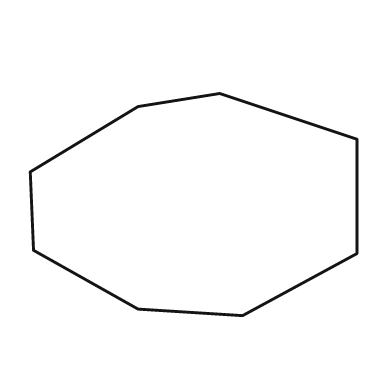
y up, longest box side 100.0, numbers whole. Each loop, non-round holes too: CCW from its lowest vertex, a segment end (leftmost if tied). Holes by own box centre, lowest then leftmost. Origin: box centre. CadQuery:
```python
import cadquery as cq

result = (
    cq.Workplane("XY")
    .moveTo(15.0, -34.0)
    .lineTo(50.0, -15.0)
    .lineTo(50.0, 20.0)
    .lineTo(8.0, 34.0)
    .lineTo(-17.0, 30.0)
    .lineTo(-50.0, 10.0)
    .lineTo(-49.0, -14.0)
    .lineTo(-17.0, -32.0)
    .close()
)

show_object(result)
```